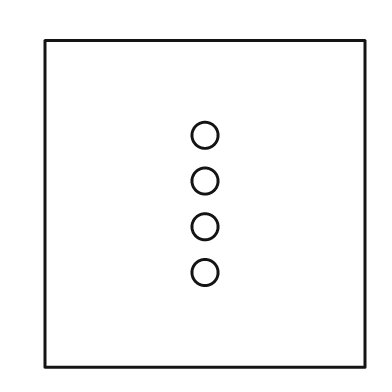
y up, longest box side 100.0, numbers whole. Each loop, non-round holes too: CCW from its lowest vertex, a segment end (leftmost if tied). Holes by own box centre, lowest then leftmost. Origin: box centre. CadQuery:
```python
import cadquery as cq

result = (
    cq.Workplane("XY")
    .moveTo(-49.0, -50.0)
    .lineTo(49.0, -50.0)
    .lineTo(49.0, 50.0)
    .lineTo(-49.0, 50.0)
    .close()
    .moveTo(0.0, -21.0)
    .circle(4.0)
    .moveTo(0.0, -7.0)
    .circle(4.0)
    .moveTo(0.0, 7.0)
    .circle(4.0)
    .moveTo(0.0, 21.0)
    .circle(4.0)
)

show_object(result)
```